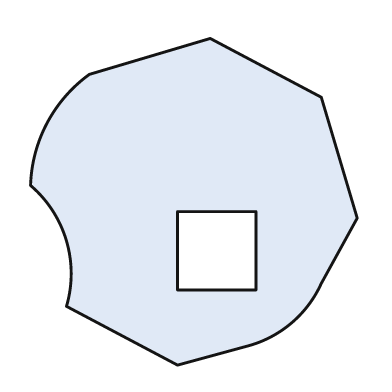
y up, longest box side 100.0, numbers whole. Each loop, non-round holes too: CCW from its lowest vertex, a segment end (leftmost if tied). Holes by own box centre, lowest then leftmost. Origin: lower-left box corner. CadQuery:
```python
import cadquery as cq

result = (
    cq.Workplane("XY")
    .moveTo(45.0, 0.0)
    .lineTo(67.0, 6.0)
    .threePointArc((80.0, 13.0), (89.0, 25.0))
    .lineTo(100.0, 45.0)
    .lineTo(89.0, 82.0)
    .lineTo(55.0, 100.0)
    .lineTo(18.0, 89.0)
    .threePointArc((5.0, 74.0), (0.0, 55.0))
    .threePointArc((11.0, 38.0), (11.0, 18.0))
    .close()
    .moveTo(45.0, 23.0)
    .lineTo(69.0, 23.0)
    .lineTo(69.0, 47.0)
    .lineTo(45.0, 47.0)
    .close()
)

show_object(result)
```